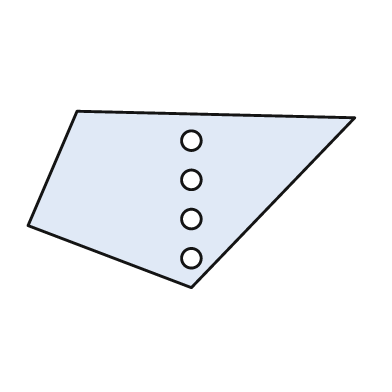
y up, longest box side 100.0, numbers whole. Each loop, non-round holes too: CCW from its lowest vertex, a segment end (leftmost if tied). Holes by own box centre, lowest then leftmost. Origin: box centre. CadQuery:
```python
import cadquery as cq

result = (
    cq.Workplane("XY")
    .moveTo(0.0, -27.0)
    .lineTo(50.0, 25.0)
    .lineTo(-35.0, 27.0)
    .lineTo(-50.0, -8.0)
    .close()
    .moveTo(0.0, -18.0)
    .circle(3.0)
    .moveTo(0.0, -6.0)
    .circle(3.0)
    .moveTo(0.0, 6.0)
    .circle(3.0)
    .moveTo(0.0, 18.0)
    .circle(3.0)
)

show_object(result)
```